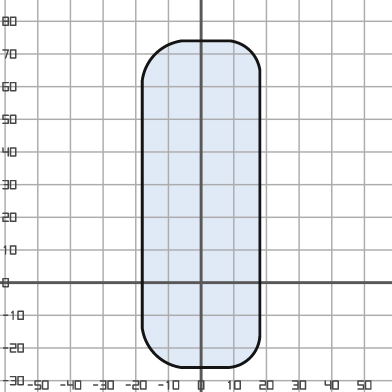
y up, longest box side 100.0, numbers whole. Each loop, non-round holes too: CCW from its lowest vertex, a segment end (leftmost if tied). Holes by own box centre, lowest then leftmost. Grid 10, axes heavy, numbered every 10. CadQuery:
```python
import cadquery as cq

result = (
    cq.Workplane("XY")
    .moveTo(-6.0, -26.0)
    .lineTo(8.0, -26.0)
    .threePointArc((15.0, -23.0), (18.0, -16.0))
    .lineTo(18.0, 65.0)
    .threePointArc((15.0, 71.0), (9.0, 74.0))
    .lineTo(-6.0, 74.0)
    .threePointArc((-14.0, 70.0), (-18.0, 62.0))
    .lineTo(-18.0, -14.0)
    .threePointArc((-14.0, -22.0), (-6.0, -26.0))
    .close()
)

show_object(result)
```